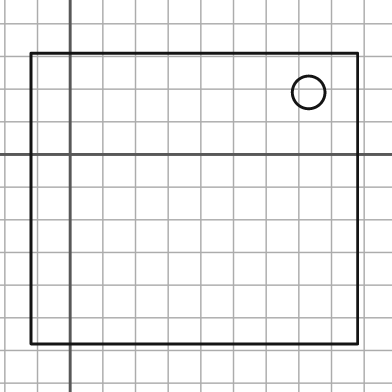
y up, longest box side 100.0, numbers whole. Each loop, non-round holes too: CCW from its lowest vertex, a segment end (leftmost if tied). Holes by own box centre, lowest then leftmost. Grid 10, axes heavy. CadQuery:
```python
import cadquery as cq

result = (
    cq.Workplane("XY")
    .moveTo(-12.0, -58.0)
    .lineTo(88.0, -58.0)
    .lineTo(88.0, 31.0)
    .lineTo(-12.0, 31.0)
    .close()
    .moveTo(73.0, 19.0)
    .circle(5.0)
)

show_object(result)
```